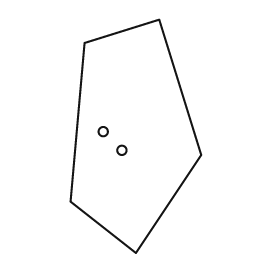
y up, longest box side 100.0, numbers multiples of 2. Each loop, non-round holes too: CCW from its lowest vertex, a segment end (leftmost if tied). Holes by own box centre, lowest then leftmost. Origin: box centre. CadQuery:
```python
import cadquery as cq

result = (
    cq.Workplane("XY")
    .moveTo(0.0, -50.0)
    .lineTo(28.0, -8.0)
    .lineTo(10.0, 50.0)
    .lineTo(-22.0, 40.0)
    .lineTo(-28.0, -28.0)
    .close()
    .moveTo(-6.0, -6.0)
    .circle(2.0)
    .moveTo(-14.0, 2.0)
    .circle(2.0)
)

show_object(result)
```